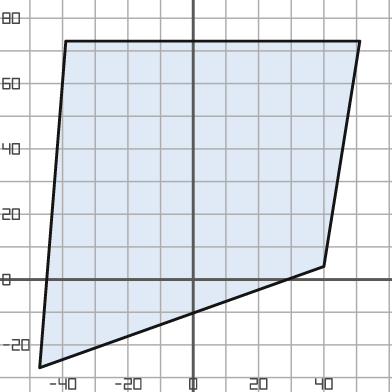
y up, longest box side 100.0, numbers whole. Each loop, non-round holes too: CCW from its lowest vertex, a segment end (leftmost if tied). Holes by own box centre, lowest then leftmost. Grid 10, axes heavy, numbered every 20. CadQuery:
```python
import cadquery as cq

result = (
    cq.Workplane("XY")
    .moveTo(-47.0, -27.0)
    .lineTo(40.0, 4.0)
    .lineTo(51.0, 73.0)
    .lineTo(-39.0, 73.0)
    .close()
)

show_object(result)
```